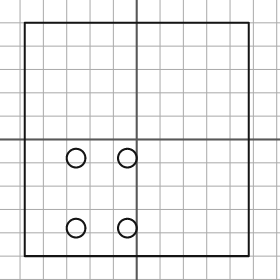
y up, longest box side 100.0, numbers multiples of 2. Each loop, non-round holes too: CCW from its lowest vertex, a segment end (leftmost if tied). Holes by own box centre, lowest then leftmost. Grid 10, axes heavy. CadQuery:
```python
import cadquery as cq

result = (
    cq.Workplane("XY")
    .moveTo(-48.0, -50.0)
    .lineTo(48.0, -50.0)
    .lineTo(48.0, 50.0)
    .lineTo(-48.0, 50.0)
    .close()
    .moveTo(-26.0, -38.0)
    .circle(4.0)
    .moveTo(-4.0, -38.0)
    .circle(4.0)
    .moveTo(-26.0, -8.0)
    .circle(4.0)
    .moveTo(-4.0, -8.0)
    .circle(4.0)
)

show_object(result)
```